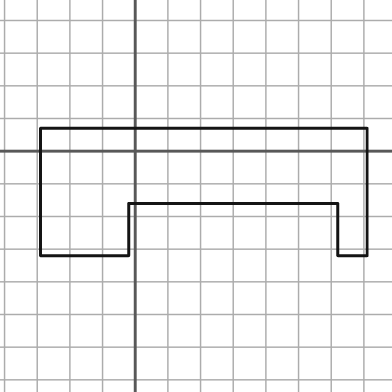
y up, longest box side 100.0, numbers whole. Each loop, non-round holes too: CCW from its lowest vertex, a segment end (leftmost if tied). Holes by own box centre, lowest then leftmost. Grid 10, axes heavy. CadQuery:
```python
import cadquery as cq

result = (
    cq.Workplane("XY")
    .moveTo(-29.0, -32.0)
    .lineTo(-2.0, -32.0)
    .lineTo(-2.0, -16.0)
    .lineTo(62.0, -16.0)
    .lineTo(62.0, -32.0)
    .lineTo(71.0, -32.0)
    .lineTo(71.0, 7.0)
    .lineTo(-29.0, 7.0)
    .close()
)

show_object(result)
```